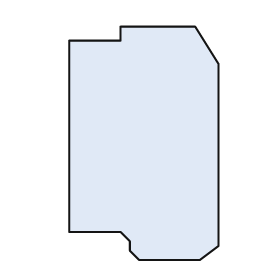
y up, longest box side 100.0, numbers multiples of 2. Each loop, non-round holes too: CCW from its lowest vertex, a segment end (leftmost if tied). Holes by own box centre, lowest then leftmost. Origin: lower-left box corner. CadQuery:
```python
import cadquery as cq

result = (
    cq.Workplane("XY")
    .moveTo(30.0, 0.0)
    .lineTo(56.0, 0.0)
    .lineTo(64.0, 6.0)
    .lineTo(64.0, 84.0)
    .lineTo(54.0, 100.0)
    .lineTo(22.0, 100.0)
    .lineTo(22.0, 94.0)
    .lineTo(0.0, 94.0)
    .lineTo(0.0, 12.0)
    .lineTo(22.0, 12.0)
    .lineTo(26.0, 8.0)
    .lineTo(26.0, 4.0)
    .close()
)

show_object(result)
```